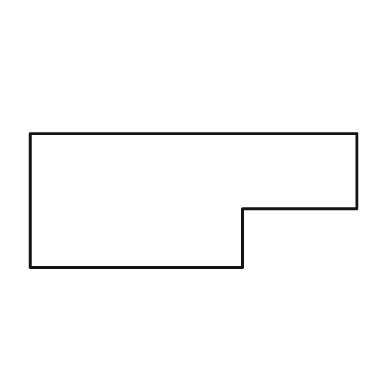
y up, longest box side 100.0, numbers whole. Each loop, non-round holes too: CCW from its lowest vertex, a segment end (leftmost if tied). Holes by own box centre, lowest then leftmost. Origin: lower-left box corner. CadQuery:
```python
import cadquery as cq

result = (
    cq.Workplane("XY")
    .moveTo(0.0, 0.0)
    .lineTo(65.0, 0.0)
    .lineTo(65.0, 18.0)
    .lineTo(100.0, 18.0)
    .lineTo(100.0, 41.0)
    .lineTo(0.0, 41.0)
    .close()
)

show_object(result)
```